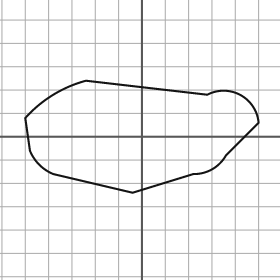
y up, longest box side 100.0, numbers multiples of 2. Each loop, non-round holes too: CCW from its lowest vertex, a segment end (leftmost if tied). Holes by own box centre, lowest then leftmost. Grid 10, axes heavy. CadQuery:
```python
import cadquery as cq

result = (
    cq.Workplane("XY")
    .moveTo(-4.0, -24.0)
    .lineTo(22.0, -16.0)
    .threePointArc((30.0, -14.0), (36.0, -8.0))
    .lineTo(50.0, 6.0)
    .threePointArc((42.0, 18.0), (28.0, 18.0))
    .lineTo(-24.0, 24.0)
    .threePointArc((-38.0, 18.0), (-50.0, 8.0))
    .lineTo(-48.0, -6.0)
    .threePointArc((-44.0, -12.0), (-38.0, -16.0))
    .close()
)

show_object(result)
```